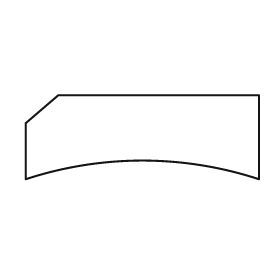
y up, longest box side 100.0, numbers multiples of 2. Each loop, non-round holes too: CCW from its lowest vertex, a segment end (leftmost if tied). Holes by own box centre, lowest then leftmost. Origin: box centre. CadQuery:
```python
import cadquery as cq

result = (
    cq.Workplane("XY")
    .moveTo(-50.0, -18.0)
    .threePointArc((0.0, -10.0), (50.0, -18.0))
    .lineTo(50.0, 18.0)
    .lineTo(-36.0, 18.0)
    .lineTo(-50.0, 6.0)
    .close()
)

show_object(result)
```